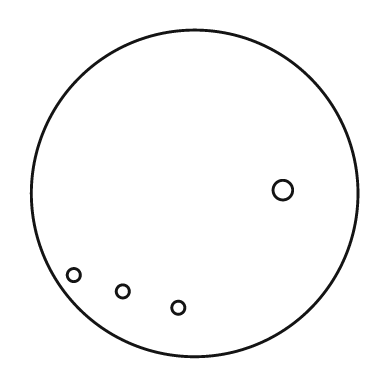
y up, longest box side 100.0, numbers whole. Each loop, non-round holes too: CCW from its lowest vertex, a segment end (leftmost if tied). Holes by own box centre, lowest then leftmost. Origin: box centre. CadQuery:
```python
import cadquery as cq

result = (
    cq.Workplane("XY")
    .moveTo(0.0, 0.0)
    .circle(50.0)
    .moveTo(-5.0, -35.0)
    .circle(2.0)
    .moveTo(-22.0, -30.0)
    .circle(2.0)
    .moveTo(-37.0, -25.0)
    .circle(2.0)
    .moveTo(27.0, 1.0)
    .circle(3.0)
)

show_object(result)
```